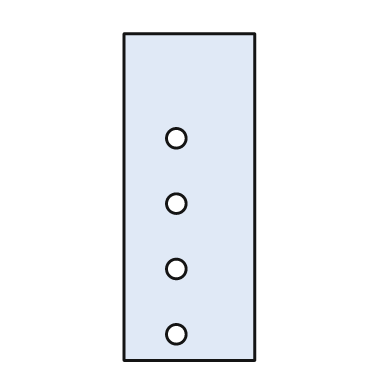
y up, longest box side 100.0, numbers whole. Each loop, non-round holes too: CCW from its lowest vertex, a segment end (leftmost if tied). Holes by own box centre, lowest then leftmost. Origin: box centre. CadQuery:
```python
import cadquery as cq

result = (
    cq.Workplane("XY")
    .moveTo(-20.0, -50.0)
    .lineTo(20.0, -50.0)
    .lineTo(20.0, 50.0)
    .lineTo(-20.0, 50.0)
    .close()
    .moveTo(-4.0, -42.0)
    .circle(3.0)
    .moveTo(-4.0, -22.0)
    .circle(3.0)
    .moveTo(-4.0, -2.0)
    .circle(3.0)
    .moveTo(-4.0, 18.0)
    .circle(3.0)
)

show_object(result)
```